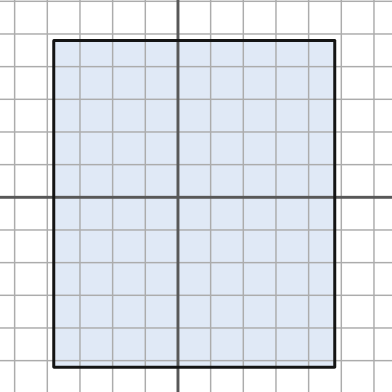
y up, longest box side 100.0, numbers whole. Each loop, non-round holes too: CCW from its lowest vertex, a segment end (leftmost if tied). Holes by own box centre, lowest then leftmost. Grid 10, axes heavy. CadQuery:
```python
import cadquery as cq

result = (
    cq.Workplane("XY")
    .moveTo(-38.0, -52.0)
    .lineTo(48.0, -52.0)
    .lineTo(48.0, 48.0)
    .lineTo(-38.0, 48.0)
    .close()
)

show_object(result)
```